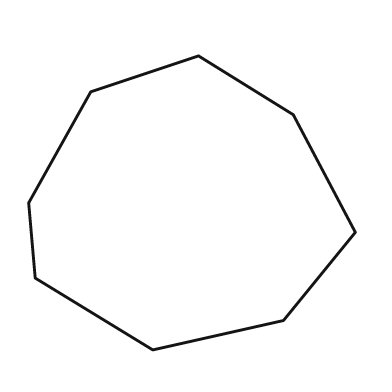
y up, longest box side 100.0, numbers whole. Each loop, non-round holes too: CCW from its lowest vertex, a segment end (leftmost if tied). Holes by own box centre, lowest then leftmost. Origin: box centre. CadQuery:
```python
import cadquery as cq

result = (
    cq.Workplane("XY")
    .moveTo(-12.0, -45.0)
    .lineTo(28.0, -36.0)
    .lineTo(50.0, -9.0)
    .lineTo(31.0, 27.0)
    .lineTo(2.0, 45.0)
    .lineTo(-31.0, 34.0)
    .lineTo(-50.0, 0.0)
    .lineTo(-48.0, -23.0)
    .close()
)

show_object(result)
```